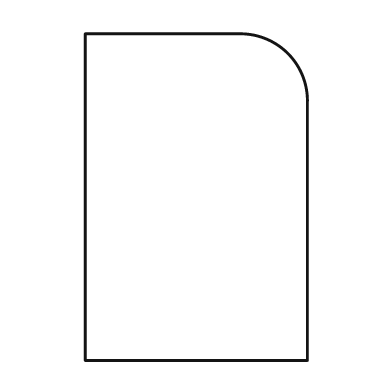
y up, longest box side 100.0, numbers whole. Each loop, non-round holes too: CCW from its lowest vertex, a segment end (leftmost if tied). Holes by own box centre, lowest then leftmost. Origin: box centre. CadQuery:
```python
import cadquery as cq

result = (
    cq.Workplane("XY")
    .moveTo(-34.0, -50.0)
    .lineTo(34.0, -50.0)
    .lineTo(34.0, 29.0)
    .threePointArc((28.0, 44.0), (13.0, 50.0))
    .lineTo(-34.0, 50.0)
    .close()
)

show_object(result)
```